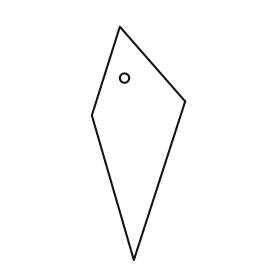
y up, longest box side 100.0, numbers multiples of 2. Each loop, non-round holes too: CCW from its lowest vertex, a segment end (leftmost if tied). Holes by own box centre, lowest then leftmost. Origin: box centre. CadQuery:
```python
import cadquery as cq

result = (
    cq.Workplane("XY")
    .moveTo(-2.0, -50.0)
    .lineTo(20.0, 18.0)
    .lineTo(-8.0, 50.0)
    .lineTo(-20.0, 12.0)
    .close()
    .moveTo(-6.0, 28.0)
    .circle(2.0)
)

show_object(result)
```